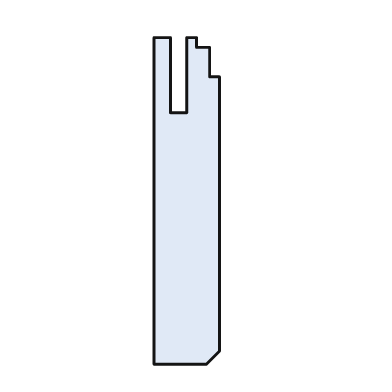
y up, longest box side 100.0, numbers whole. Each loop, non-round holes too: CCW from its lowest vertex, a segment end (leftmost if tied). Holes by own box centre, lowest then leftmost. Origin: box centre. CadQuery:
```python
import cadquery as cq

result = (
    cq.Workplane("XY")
    .moveTo(-10.0, -50.0)
    .lineTo(6.0, -50.0)
    .lineTo(10.0, -46.0)
    .lineTo(10.0, 38.0)
    .lineTo(7.0, 38.0)
    .lineTo(7.0, 47.0)
    .lineTo(3.0, 47.0)
    .lineTo(3.0, 50.0)
    .lineTo(0.0, 50.0)
    .lineTo(0.0, 27.0)
    .lineTo(-5.0, 27.0)
    .lineTo(-5.0, 50.0)
    .lineTo(-10.0, 50.0)
    .close()
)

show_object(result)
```